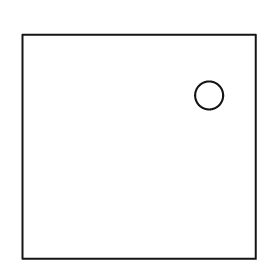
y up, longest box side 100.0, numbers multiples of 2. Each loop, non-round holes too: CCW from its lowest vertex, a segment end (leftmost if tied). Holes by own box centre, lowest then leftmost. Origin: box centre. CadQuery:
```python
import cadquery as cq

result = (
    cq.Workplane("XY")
    .moveTo(-50.0, -48.0)
    .lineTo(50.0, -48.0)
    .lineTo(50.0, 48.0)
    .lineTo(-50.0, 48.0)
    .close()
    .moveTo(30.0, 22.0)
    .circle(6.0)
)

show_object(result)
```